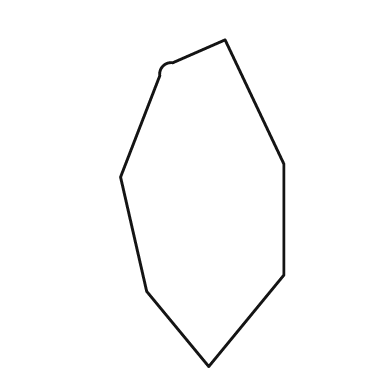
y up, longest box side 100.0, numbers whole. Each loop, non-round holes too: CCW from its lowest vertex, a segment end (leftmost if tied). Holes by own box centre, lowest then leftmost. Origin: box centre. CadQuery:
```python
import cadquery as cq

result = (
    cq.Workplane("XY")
    .moveTo(2.0, -50.0)
    .lineTo(25.0, -22.0)
    .lineTo(25.0, 12.0)
    .lineTo(7.0, 50.0)
    .lineTo(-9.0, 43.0)
    .threePointArc((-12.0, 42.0), (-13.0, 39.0))
    .lineTo(-25.0, 8.0)
    .lineTo(-17.0, -27.0)
    .close()
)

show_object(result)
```